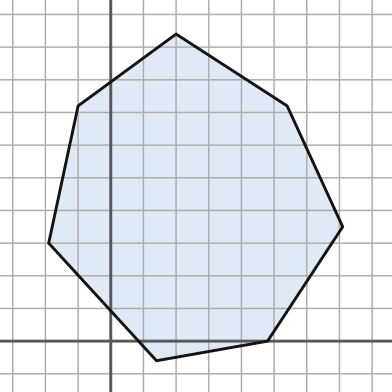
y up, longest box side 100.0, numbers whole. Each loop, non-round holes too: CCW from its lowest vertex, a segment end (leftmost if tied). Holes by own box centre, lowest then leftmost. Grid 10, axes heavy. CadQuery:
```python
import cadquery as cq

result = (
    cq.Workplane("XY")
    .moveTo(14.0, -6.0)
    .lineTo(48.0, 0.0)
    .lineTo(71.0, 35.0)
    .lineTo(54.0, 72.0)
    .lineTo(20.0, 94.0)
    .lineTo(-10.0, 72.0)
    .lineTo(-19.0, 30.0)
    .close()
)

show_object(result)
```